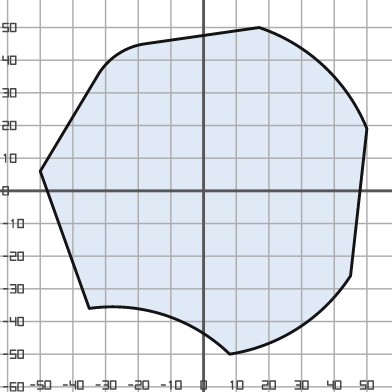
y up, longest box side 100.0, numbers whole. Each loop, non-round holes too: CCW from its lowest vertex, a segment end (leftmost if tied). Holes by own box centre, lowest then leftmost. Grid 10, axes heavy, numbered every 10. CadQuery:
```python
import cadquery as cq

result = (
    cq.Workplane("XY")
    .moveTo(8.0, -50.0)
    .threePointArc((29.0, -42.0), (45.0, -26.0))
    .lineTo(50.0, 19.0)
    .threePointArc((37.0, 38.0), (17.0, 50.0))
    .lineTo(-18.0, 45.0)
    .threePointArc((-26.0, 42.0), (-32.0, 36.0))
    .lineTo(-50.0, 6.0)
    .lineTo(-35.0, -36.0)
    .threePointArc((-12.0, -38.0), (8.0, -50.0))
    .close()
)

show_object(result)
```